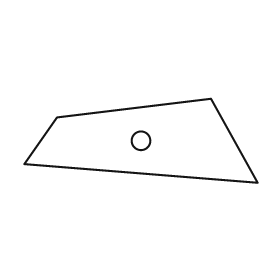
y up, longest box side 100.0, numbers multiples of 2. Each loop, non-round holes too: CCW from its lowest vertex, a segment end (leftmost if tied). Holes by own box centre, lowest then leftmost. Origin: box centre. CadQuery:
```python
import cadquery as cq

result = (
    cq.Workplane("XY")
    .moveTo(50.0, -18.0)
    .lineTo(30.0, 18.0)
    .lineTo(-36.0, 10.0)
    .lineTo(-50.0, -10.0)
    .close()
    .moveTo(0.0, 0.0)
    .circle(4.0)
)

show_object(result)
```